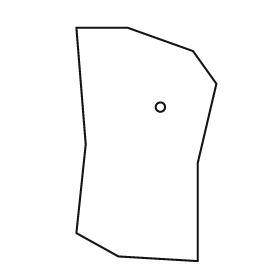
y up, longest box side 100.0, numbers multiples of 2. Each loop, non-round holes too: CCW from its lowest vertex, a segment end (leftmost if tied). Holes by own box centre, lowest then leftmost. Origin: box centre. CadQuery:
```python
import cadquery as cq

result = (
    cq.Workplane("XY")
    .moveTo(22.0, -50.0)
    .lineTo(22.0, -8.0)
    .lineTo(30.0, 26.0)
    .lineTo(20.0, 40.0)
    .lineTo(-8.0, 50.0)
    .lineTo(-30.0, 50.0)
    .lineTo(-26.0, 0.0)
    .lineTo(-30.0, -38.0)
    .lineTo(-12.0, -48.0)
    .close()
    .moveTo(6.0, 16.0)
    .circle(2.0)
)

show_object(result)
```